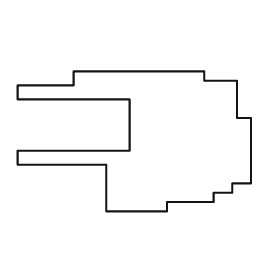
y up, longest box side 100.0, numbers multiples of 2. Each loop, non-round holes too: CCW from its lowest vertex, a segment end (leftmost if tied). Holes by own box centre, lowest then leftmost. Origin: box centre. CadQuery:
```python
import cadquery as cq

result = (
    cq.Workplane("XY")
    .moveTo(-12.0, -30.0)
    .lineTo(14.0, -30.0)
    .lineTo(14.0, -26.0)
    .lineTo(34.0, -26.0)
    .lineTo(34.0, -22.0)
    .lineTo(42.0, -22.0)
    .lineTo(42.0, -18.0)
    .lineTo(50.0, -18.0)
    .lineTo(50.0, 10.0)
    .lineTo(44.0, 10.0)
    .lineTo(44.0, 26.0)
    .lineTo(30.0, 26.0)
    .lineTo(30.0, 30.0)
    .lineTo(-26.0, 30.0)
    .lineTo(-26.0, 24.0)
    .lineTo(-50.0, 24.0)
    .lineTo(-50.0, 18.0)
    .lineTo(-2.0, 18.0)
    .lineTo(-2.0, -4.0)
    .lineTo(-50.0, -4.0)
    .lineTo(-50.0, -10.0)
    .lineTo(-12.0, -10.0)
    .close()
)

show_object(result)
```